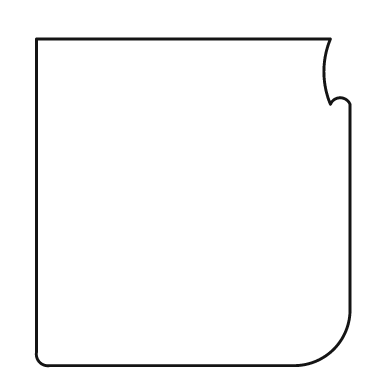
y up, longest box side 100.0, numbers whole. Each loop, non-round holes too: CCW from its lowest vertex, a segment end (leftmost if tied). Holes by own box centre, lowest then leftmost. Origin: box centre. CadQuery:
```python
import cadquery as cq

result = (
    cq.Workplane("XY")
    .moveTo(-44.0, -50.0)
    .lineTo(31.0, -50.0)
    .threePointArc((43.0, -45.0), (48.0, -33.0))
    .lineTo(48.0, 30.0)
    .threePointArc((45.0, 32.0), (42.0, 30.0))
    .threePointArc((40.0, 40.0), (42.0, 50.0))
    .lineTo(-48.0, 50.0)
    .lineTo(-48.0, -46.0)
    .threePointArc((-47.0, -49.0), (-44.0, -50.0))
    .close()
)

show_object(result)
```